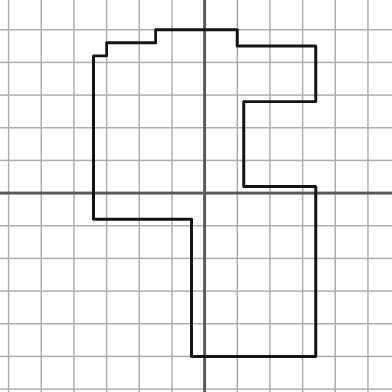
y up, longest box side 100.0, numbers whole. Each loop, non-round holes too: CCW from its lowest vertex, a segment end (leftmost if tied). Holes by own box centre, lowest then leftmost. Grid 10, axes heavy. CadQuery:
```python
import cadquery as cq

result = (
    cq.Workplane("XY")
    .moveTo(-4.0, -50.0)
    .lineTo(34.0, -50.0)
    .lineTo(34.0, 2.0)
    .lineTo(12.0, 2.0)
    .lineTo(12.0, 28.0)
    .lineTo(34.0, 28.0)
    .lineTo(34.0, 45.0)
    .lineTo(10.0, 45.0)
    .lineTo(10.0, 50.0)
    .lineTo(-15.0, 50.0)
    .lineTo(-15.0, 46.0)
    .lineTo(-30.0, 46.0)
    .lineTo(-30.0, 42.0)
    .lineTo(-34.0, 42.0)
    .lineTo(-34.0, -8.0)
    .lineTo(-4.0, -8.0)
    .close()
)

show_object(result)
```